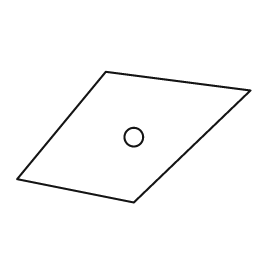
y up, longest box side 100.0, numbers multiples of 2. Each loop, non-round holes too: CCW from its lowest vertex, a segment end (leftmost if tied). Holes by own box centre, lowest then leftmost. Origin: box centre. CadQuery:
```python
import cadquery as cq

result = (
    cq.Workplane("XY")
    .moveTo(0.0, -28.0)
    .lineTo(50.0, 20.0)
    .lineTo(-12.0, 28.0)
    .lineTo(-50.0, -18.0)
    .close()
    .moveTo(0.0, 0.0)
    .circle(4.0)
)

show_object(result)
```